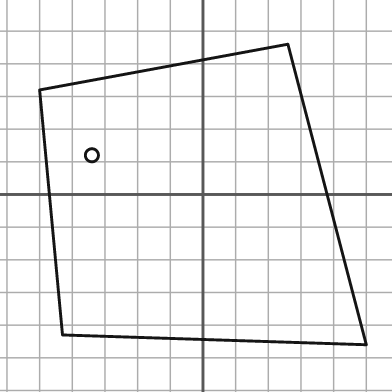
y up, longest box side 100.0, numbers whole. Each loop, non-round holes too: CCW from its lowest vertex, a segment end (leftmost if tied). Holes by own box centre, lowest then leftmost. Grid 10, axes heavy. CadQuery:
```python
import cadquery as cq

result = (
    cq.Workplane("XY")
    .moveTo(50.0, -46.0)
    .lineTo(26.0, 46.0)
    .lineTo(-50.0, 32.0)
    .lineTo(-43.0, -43.0)
    .close()
    .moveTo(-34.0, 12.0)
    .circle(2.0)
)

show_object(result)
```